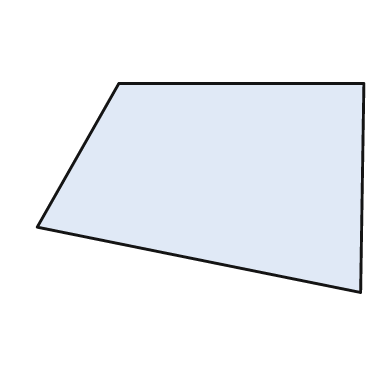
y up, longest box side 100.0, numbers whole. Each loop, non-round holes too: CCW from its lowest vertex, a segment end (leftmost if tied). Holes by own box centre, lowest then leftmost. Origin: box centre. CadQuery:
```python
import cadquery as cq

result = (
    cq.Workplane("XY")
    .moveTo(49.0, -32.0)
    .lineTo(50.0, 32.0)
    .lineTo(-25.0, 32.0)
    .lineTo(-50.0, -12.0)
    .close()
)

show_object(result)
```